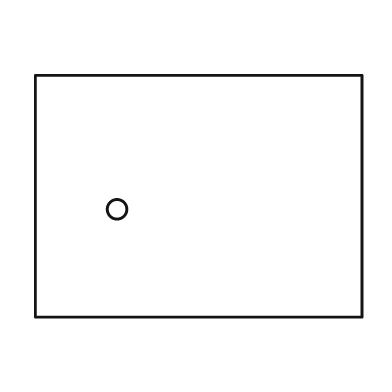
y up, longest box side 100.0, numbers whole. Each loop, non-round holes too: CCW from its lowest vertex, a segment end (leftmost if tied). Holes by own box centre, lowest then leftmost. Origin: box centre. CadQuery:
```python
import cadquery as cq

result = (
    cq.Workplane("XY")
    .moveTo(-50.0, -37.0)
    .lineTo(50.0, -37.0)
    .lineTo(50.0, 37.0)
    .lineTo(-50.0, 37.0)
    .close()
    .moveTo(-25.0, -4.0)
    .circle(3.0)
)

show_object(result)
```